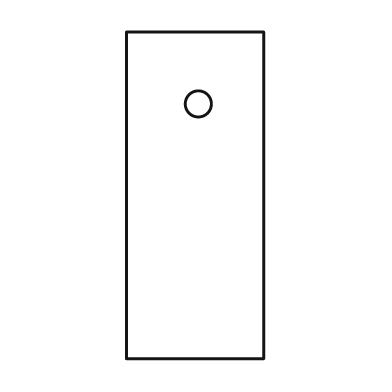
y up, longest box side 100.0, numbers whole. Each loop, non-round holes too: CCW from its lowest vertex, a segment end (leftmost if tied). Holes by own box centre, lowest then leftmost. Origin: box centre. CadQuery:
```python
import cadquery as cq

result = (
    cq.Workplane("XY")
    .moveTo(-21.0, -50.0)
    .lineTo(21.0, -50.0)
    .lineTo(21.0, 50.0)
    .lineTo(-21.0, 50.0)
    .close()
    .moveTo(1.0, 28.0)
    .circle(4.0)
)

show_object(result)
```